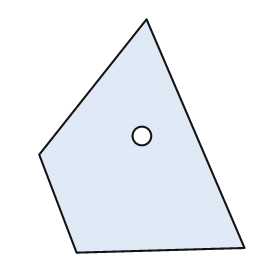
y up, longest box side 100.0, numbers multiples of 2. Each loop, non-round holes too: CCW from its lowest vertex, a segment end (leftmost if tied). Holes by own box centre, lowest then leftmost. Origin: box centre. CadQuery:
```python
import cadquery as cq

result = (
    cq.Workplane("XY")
    .moveTo(-28.0, -50.0)
    .lineTo(44.0, -48.0)
    .lineTo(2.0, 50.0)
    .lineTo(-44.0, -8.0)
    .close()
    .moveTo(0.0, 0.0)
    .circle(4.0)
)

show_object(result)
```